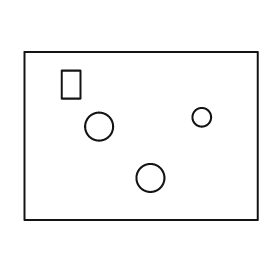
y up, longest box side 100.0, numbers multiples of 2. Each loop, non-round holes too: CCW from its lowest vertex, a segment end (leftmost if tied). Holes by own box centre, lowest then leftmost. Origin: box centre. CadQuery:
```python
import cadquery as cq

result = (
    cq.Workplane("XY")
    .moveTo(-50.0, -36.0)
    .lineTo(50.0, -36.0)
    .lineTo(50.0, 36.0)
    .lineTo(-50.0, 36.0)
    .close()
    .moveTo(4.0, -18.0)
    .circle(6.0)
    .moveTo(-18.0, 4.0)
    .circle(6.0)
    .moveTo(26.0, 8.0)
    .circle(4.0)
    .moveTo(-34.0, 16.0)
    .lineTo(-26.0, 16.0)
    .lineTo(-26.0, 28.0)
    .lineTo(-34.0, 28.0)
    .close()
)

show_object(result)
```